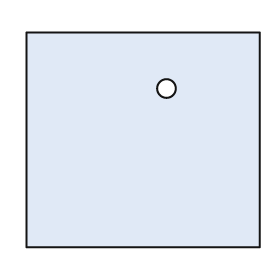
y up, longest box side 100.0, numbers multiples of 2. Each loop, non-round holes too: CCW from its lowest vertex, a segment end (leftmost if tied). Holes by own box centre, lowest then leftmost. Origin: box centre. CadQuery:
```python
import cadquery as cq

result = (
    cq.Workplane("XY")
    .moveTo(-50.0, -46.0)
    .lineTo(50.0, -46.0)
    .lineTo(50.0, 46.0)
    .lineTo(-50.0, 46.0)
    .close()
    .moveTo(10.0, 22.0)
    .circle(4.0)
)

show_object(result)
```